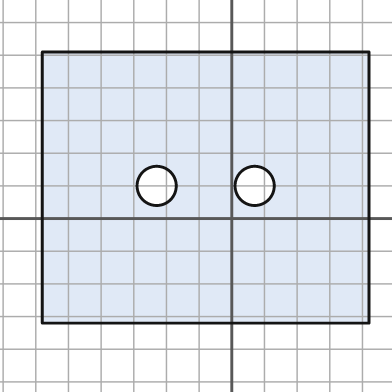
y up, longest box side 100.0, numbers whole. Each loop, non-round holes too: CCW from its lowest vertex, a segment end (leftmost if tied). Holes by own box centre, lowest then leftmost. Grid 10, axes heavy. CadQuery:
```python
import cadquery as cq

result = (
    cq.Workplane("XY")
    .moveTo(-58.0, -32.0)
    .lineTo(42.0, -32.0)
    .lineTo(42.0, 51.0)
    .lineTo(-58.0, 51.0)
    .close()
    .moveTo(-23.0, 10.0)
    .circle(6.0)
    .moveTo(7.0, 10.0)
    .circle(6.0)
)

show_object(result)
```